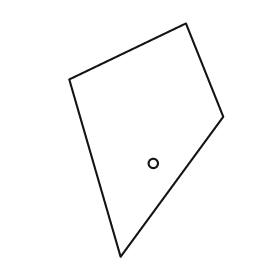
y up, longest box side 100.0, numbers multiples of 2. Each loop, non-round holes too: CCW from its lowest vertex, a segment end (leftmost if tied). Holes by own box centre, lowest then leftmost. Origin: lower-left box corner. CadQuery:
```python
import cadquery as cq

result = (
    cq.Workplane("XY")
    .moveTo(22.0, 0.0)
    .lineTo(66.0, 60.0)
    .lineTo(50.0, 100.0)
    .lineTo(0.0, 76.0)
    .close()
    .moveTo(36.0, 40.0)
    .circle(2.0)
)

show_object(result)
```